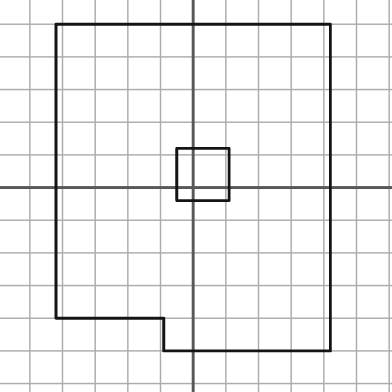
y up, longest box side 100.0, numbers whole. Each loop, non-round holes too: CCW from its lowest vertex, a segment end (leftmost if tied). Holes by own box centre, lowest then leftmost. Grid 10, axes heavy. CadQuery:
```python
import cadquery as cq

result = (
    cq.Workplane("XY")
    .moveTo(-9.0, -50.0)
    .lineTo(42.0, -50.0)
    .lineTo(42.0, 50.0)
    .lineTo(-42.0, 50.0)
    .lineTo(-42.0, -40.0)
    .lineTo(-9.0, -40.0)
    .close()
    .moveTo(-5.0, -4.0)
    .lineTo(11.0, -4.0)
    .lineTo(11.0, 12.0)
    .lineTo(-5.0, 12.0)
    .close()
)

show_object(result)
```